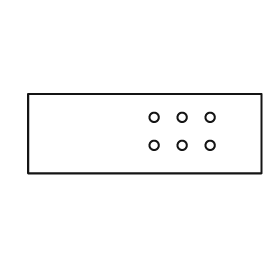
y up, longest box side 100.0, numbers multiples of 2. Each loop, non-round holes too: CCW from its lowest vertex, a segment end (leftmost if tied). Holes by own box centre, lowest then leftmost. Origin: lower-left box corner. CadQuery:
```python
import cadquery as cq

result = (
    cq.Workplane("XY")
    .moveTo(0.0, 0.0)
    .lineTo(100.0, 0.0)
    .lineTo(100.0, 34.0)
    .lineTo(0.0, 34.0)
    .close()
    .moveTo(54.0, 12.0)
    .circle(2.0)
    .moveTo(66.0, 12.0)
    .circle(2.0)
    .moveTo(78.0, 12.0)
    .circle(2.0)
    .moveTo(54.0, 24.0)
    .circle(2.0)
    .moveTo(66.0, 24.0)
    .circle(2.0)
    .moveTo(78.0, 24.0)
    .circle(2.0)
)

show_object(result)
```